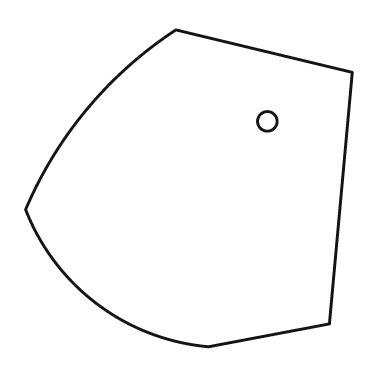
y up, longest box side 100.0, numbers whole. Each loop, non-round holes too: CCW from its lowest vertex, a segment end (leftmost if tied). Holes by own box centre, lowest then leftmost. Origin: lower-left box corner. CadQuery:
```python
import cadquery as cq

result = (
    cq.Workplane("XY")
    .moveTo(56.0, 0.0)
    .lineTo(93.0, 7.0)
    .lineTo(100.0, 84.0)
    .lineTo(46.0, 97.0)
    .threePointArc((19.0, 73.0), (0.0, 42.0))
    .threePointArc((22.0, 13.0), (56.0, 0.0))
    .close()
    .moveTo(74.0, 69.0)
    .circle(3.0)
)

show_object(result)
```